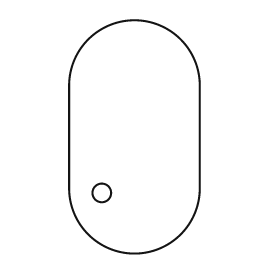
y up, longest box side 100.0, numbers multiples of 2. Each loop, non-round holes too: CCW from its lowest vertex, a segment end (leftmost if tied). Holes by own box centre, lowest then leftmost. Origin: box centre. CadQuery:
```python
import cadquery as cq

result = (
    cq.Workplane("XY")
    .moveTo(-28.0, -22.0)
    .threePointArc((0.0, -50.0), (28.0, -22.0))
    .lineTo(28.0, 22.0)
    .threePointArc((0.0, 50.0), (-28.0, 22.0))
    .close()
    .moveTo(-14.0, -24.0)
    .circle(4.0)
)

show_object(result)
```